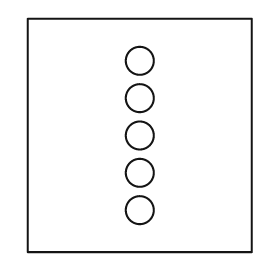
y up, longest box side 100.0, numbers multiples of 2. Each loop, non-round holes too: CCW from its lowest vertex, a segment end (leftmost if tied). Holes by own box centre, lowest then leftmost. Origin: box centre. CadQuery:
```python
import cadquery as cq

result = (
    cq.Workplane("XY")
    .moveTo(-48.0, -50.0)
    .lineTo(48.0, -50.0)
    .lineTo(48.0, 50.0)
    .lineTo(-48.0, 50.0)
    .close()
    .moveTo(0.0, -32.0)
    .circle(6.0)
    .moveTo(0.0, -16.0)
    .circle(6.0)
    .moveTo(0.0, 0.0)
    .circle(6.0)
    .moveTo(0.0, 16.0)
    .circle(6.0)
    .moveTo(0.0, 32.0)
    .circle(6.0)
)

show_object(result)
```